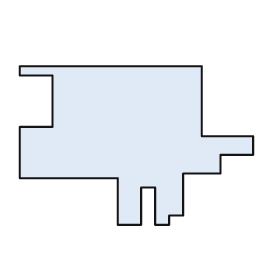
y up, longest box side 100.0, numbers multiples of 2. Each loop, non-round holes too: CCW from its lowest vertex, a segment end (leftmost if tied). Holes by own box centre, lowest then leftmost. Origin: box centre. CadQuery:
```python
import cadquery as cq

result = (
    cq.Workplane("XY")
    .moveTo(-8.0, -34.0)
    .lineTo(2.0, -34.0)
    .lineTo(2.0, -18.0)
    .lineTo(8.0, -18.0)
    .lineTo(8.0, -34.0)
    .lineTo(14.0, -34.0)
    .lineTo(14.0, -30.0)
    .lineTo(20.0, -30.0)
    .lineTo(20.0, -12.0)
    .lineTo(36.0, -12.0)
    .lineTo(36.0, -4.0)
    .lineTo(50.0, -4.0)
    .lineTo(50.0, 4.0)
    .lineTo(28.0, 4.0)
    .lineTo(28.0, 34.0)
    .lineTo(-50.0, 34.0)
    .lineTo(-50.0, 30.0)
    .lineTo(-36.0, 30.0)
    .lineTo(-36.0, 8.0)
    .lineTo(-50.0, 8.0)
    .lineTo(-50.0, -14.0)
    .lineTo(-8.0, -14.0)
    .close()
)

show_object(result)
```